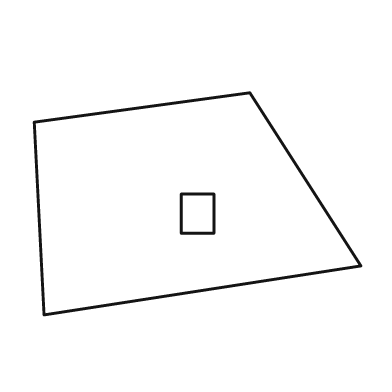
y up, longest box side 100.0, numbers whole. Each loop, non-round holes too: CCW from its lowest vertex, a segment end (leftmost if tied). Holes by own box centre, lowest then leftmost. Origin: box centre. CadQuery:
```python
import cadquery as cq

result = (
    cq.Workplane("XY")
    .moveTo(-47.0, -34.0)
    .lineTo(50.0, -19.0)
    .lineTo(16.0, 34.0)
    .lineTo(-50.0, 25.0)
    .close()
    .moveTo(-5.0, -9.0)
    .lineTo(5.0, -9.0)
    .lineTo(5.0, 3.0)
    .lineTo(-5.0, 3.0)
    .close()
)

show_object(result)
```